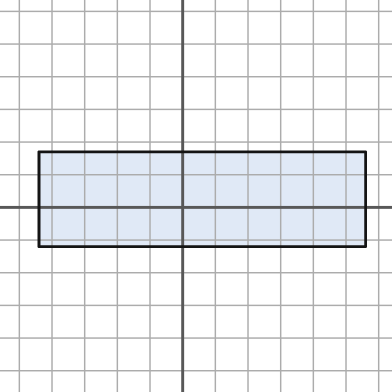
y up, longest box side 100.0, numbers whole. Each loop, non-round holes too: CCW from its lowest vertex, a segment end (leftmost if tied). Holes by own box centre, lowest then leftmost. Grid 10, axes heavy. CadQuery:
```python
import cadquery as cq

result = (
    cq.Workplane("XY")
    .moveTo(-44.0, -12.0)
    .lineTo(56.0, -12.0)
    .lineTo(56.0, 17.0)
    .lineTo(-44.0, 17.0)
    .close()
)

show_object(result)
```